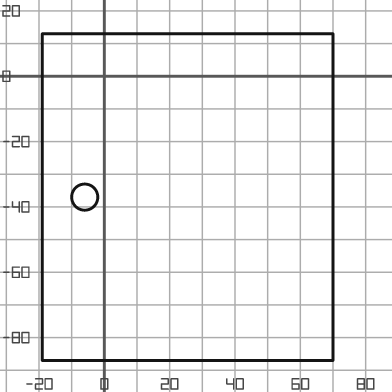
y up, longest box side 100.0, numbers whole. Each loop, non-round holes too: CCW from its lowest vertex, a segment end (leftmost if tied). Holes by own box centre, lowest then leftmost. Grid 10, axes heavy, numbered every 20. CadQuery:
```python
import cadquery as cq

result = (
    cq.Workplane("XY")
    .moveTo(-19.0, -87.0)
    .lineTo(70.0, -87.0)
    .lineTo(70.0, 13.0)
    .lineTo(-19.0, 13.0)
    .close()
    .moveTo(-6.0, -37.0)
    .circle(4.0)
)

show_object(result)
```